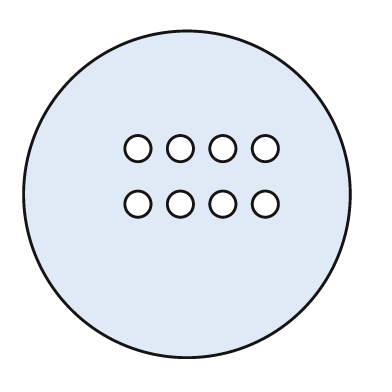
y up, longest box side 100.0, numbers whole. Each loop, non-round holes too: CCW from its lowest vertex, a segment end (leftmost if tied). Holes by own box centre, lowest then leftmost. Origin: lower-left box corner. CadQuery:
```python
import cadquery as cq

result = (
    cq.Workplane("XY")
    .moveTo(50.0, 50.0)
    .circle(50.0)
    .moveTo(35.0, 47.0)
    .circle(4.0)
    .moveTo(48.0, 47.0)
    .circle(4.0)
    .moveTo(61.0, 47.0)
    .circle(4.0)
    .moveTo(74.0, 47.0)
    .circle(4.0)
    .moveTo(35.0, 64.0)
    .circle(4.0)
    .moveTo(48.0, 64.0)
    .circle(4.0)
    .moveTo(61.0, 64.0)
    .circle(4.0)
    .moveTo(74.0, 64.0)
    .circle(4.0)
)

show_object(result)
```